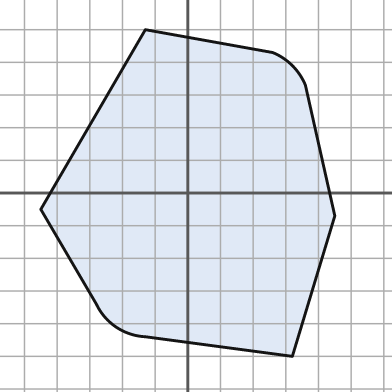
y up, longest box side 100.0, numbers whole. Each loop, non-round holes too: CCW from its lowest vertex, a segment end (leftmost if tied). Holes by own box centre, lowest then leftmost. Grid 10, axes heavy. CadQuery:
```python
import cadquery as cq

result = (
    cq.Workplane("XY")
    .moveTo(32.0, -50.0)
    .lineTo(45.0, -7.0)
    .lineTo(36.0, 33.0)
    .threePointArc((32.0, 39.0), (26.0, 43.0))
    .lineTo(-13.0, 50.0)
    .lineTo(-45.0, -5.0)
    .lineTo(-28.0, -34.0)
    .threePointArc((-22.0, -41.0), (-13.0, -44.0))
    .close()
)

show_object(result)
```